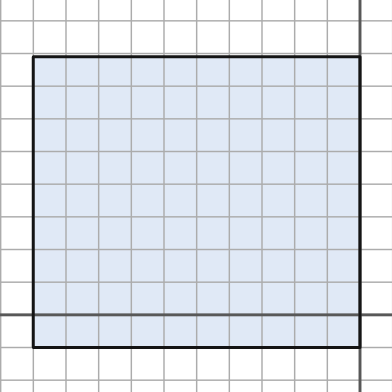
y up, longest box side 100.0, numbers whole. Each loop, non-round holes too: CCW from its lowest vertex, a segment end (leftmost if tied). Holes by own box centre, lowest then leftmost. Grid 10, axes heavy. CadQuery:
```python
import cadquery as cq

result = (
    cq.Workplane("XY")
    .moveTo(-100.0, -10.0)
    .lineTo(0.0, -10.0)
    .lineTo(0.0, 79.0)
    .lineTo(-100.0, 79.0)
    .close()
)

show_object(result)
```